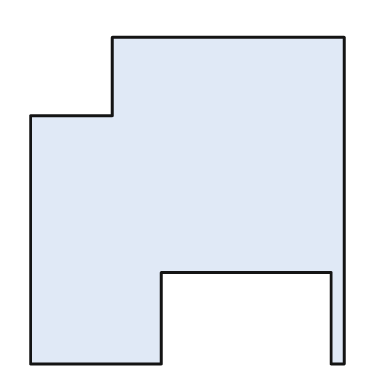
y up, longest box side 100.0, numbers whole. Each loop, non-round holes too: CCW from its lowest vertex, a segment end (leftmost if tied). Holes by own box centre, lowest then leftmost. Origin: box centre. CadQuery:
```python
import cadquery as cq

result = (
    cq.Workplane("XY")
    .moveTo(-48.0, -50.0)
    .lineTo(-8.0, -50.0)
    .lineTo(-8.0, -22.0)
    .lineTo(44.0, -22.0)
    .lineTo(44.0, -50.0)
    .lineTo(48.0, -50.0)
    .lineTo(48.0, 50.0)
    .lineTo(-23.0, 50.0)
    .lineTo(-23.0, 26.0)
    .lineTo(-48.0, 26.0)
    .close()
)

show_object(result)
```